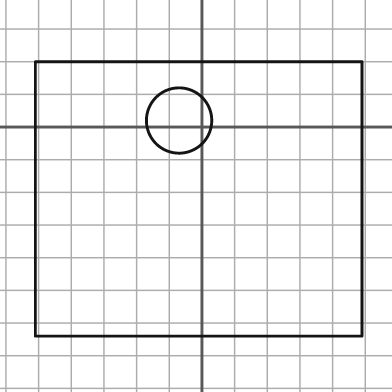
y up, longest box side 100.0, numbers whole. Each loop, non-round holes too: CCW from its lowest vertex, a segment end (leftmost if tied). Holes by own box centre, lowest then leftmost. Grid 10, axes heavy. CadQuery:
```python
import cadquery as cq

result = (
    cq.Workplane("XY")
    .moveTo(-51.0, -64.0)
    .lineTo(49.0, -64.0)
    .lineTo(49.0, 20.0)
    .lineTo(-51.0, 20.0)
    .close()
    .moveTo(-7.0, 2.0)
    .circle(10.0)
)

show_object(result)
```